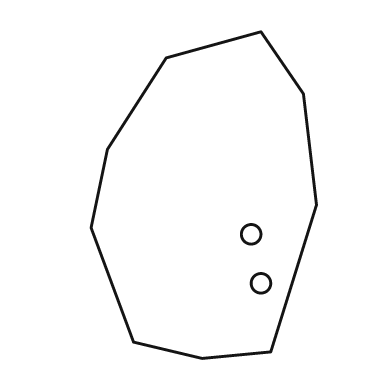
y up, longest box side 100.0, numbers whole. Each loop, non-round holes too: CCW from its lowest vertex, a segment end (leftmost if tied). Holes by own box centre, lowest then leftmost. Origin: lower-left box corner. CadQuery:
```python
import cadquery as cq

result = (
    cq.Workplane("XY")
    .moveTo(34.0, 0.0)
    .lineTo(55.0, 2.0)
    .lineTo(69.0, 47.0)
    .lineTo(65.0, 81.0)
    .lineTo(52.0, 100.0)
    .lineTo(23.0, 92.0)
    .lineTo(5.0, 64.0)
    .lineTo(0.0, 40.0)
    .lineTo(13.0, 5.0)
    .close()
    .moveTo(52.0, 23.0)
    .circle(3.0)
    .moveTo(49.0, 38.0)
    .circle(3.0)
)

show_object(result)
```